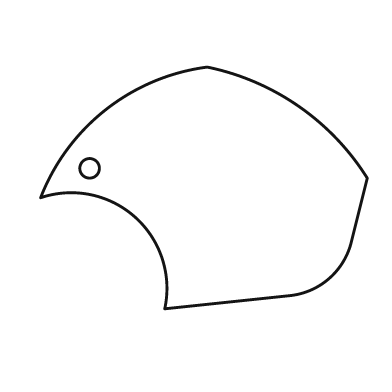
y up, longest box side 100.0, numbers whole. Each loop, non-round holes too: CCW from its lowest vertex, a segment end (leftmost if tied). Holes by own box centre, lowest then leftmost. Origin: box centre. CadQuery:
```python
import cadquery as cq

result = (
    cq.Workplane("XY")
    .moveTo(-12.0, -37.0)
    .lineTo(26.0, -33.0)
    .threePointArc((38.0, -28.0), (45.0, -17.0))
    .lineTo(50.0, 3.0)
    .threePointArc((29.0, 25.0), (1.0, 37.0))
    .threePointArc((-30.0, 24.0), (-50.0, -3.0))
    .threePointArc((-21.0, -9.0), (-12.0, -37.0))
    .close()
    .moveTo(-35.0, 6.0)
    .circle(3.0)
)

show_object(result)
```